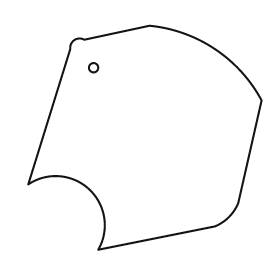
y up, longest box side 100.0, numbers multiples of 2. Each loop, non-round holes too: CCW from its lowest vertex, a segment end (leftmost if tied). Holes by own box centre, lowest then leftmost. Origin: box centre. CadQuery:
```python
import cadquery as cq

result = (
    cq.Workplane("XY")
    .moveTo(-20.0, -48.0)
    .lineTo(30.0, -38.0)
    .threePointArc((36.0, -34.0), (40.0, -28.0))
    .lineTo(50.0, 16.0)
    .threePointArc((30.0, 38.0), (2.0, 48.0))
    .lineTo(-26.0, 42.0)
    .threePointArc((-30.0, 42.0), (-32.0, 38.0))
    .lineTo(-50.0, -20.0)
    .threePointArc((-24.0, -22.0), (-20.0, -48.0))
    .close()
    .moveTo(-22.0, 30.0)
    .circle(2.0)
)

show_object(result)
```